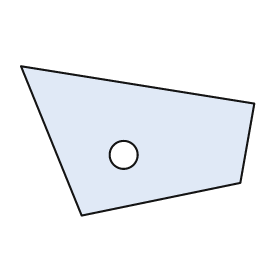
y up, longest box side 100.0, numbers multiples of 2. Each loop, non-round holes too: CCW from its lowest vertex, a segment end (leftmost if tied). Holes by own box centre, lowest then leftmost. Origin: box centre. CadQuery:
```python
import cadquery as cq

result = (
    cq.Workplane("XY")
    .moveTo(-24.0, -32.0)
    .lineTo(44.0, -18.0)
    .lineTo(50.0, 16.0)
    .lineTo(-50.0, 32.0)
    .close()
    .moveTo(-6.0, -6.0)
    .circle(6.0)
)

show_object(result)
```